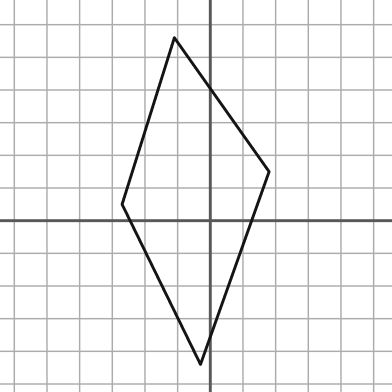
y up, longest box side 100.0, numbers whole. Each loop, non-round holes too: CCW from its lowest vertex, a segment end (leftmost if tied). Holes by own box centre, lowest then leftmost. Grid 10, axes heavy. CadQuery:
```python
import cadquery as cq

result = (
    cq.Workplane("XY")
    .moveTo(-3.0, -44.0)
    .lineTo(18.0, 15.0)
    .lineTo(-11.0, 56.0)
    .lineTo(-27.0, 5.0)
    .close()
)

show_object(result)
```